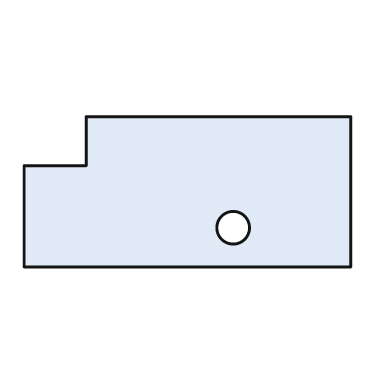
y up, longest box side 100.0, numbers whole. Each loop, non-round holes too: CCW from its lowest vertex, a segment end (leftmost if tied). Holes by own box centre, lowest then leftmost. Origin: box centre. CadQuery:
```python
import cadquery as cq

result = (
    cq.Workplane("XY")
    .moveTo(-50.0, -23.0)
    .lineTo(50.0, -23.0)
    .lineTo(50.0, 23.0)
    .lineTo(-31.0, 23.0)
    .lineTo(-31.0, 8.0)
    .lineTo(-50.0, 8.0)
    .close()
    .moveTo(14.0, -11.0)
    .circle(5.0)
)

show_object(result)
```